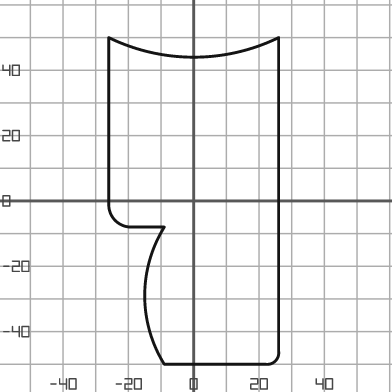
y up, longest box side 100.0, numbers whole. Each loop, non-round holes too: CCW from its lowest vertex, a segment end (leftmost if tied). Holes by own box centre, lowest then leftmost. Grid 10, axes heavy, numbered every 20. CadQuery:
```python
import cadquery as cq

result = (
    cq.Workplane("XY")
    .moveTo(-9.0, -50.0)
    .lineTo(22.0, -50.0)
    .threePointArc((25.0, -49.0), (26.0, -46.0))
    .lineTo(26.0, 50.0)
    .threePointArc((0.0, 44.0), (-26.0, 50.0))
    .lineTo(-26.0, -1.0)
    .threePointArc((-24.0, -6.0), (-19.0, -8.0))
    .lineTo(-9.0, -8.0)
    .threePointArc((-15.0, -29.0), (-9.0, -50.0))
    .close()
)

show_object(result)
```